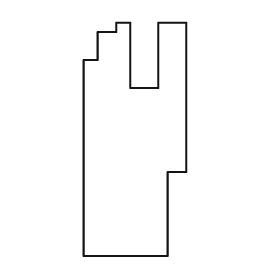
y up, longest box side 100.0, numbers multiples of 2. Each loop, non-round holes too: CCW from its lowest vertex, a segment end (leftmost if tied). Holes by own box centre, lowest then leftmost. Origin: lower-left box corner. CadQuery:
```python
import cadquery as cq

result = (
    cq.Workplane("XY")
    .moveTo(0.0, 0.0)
    .lineTo(36.0, 0.0)
    .lineTo(36.0, 36.0)
    .lineTo(44.0, 36.0)
    .lineTo(44.0, 100.0)
    .lineTo(32.0, 100.0)
    .lineTo(32.0, 72.0)
    .lineTo(20.0, 72.0)
    .lineTo(20.0, 100.0)
    .lineTo(14.0, 100.0)
    .lineTo(14.0, 96.0)
    .lineTo(6.0, 96.0)
    .lineTo(6.0, 84.0)
    .lineTo(0.0, 84.0)
    .close()
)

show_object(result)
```